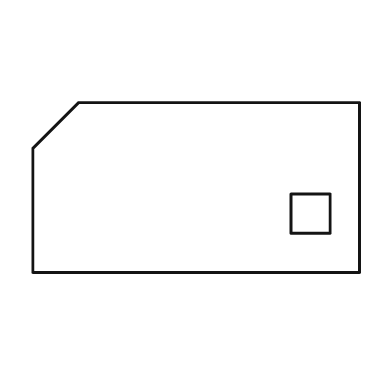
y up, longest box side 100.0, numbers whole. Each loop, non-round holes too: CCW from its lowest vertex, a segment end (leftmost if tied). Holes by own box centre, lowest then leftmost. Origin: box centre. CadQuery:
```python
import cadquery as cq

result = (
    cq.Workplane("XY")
    .moveTo(-50.0, -26.0)
    .lineTo(50.0, -26.0)
    .lineTo(50.0, 26.0)
    .lineTo(-36.0, 26.0)
    .lineTo(-50.0, 12.0)
    .close()
    .moveTo(29.0, -14.0)
    .lineTo(41.0, -14.0)
    .lineTo(41.0, -2.0)
    .lineTo(29.0, -2.0)
    .close()
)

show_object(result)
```